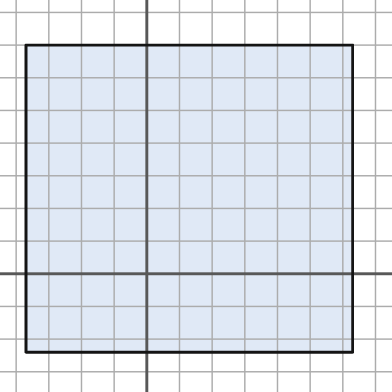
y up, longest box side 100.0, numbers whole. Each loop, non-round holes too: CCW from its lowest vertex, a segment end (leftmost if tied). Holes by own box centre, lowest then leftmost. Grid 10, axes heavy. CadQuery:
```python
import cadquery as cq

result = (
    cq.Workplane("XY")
    .moveTo(-37.0, -24.0)
    .lineTo(63.0, -24.0)
    .lineTo(63.0, 70.0)
    .lineTo(-37.0, 70.0)
    .close()
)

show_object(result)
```